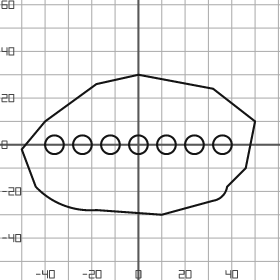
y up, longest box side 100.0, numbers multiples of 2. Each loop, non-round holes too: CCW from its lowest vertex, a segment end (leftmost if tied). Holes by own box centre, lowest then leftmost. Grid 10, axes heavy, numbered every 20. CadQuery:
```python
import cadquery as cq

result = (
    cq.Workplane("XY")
    .moveTo(10.0, -30.0)
    .lineTo(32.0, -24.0)
    .threePointArc((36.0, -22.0), (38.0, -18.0))
    .lineTo(46.0, -10.0)
    .lineTo(50.0, 10.0)
    .lineTo(32.0, 24.0)
    .lineTo(0.0, 30.0)
    .lineTo(-18.0, 26.0)
    .lineTo(-40.0, 10.0)
    .lineTo(-50.0, -2.0)
    .lineTo(-44.0, -18.0)
    .threePointArc((-32.0, -26.0), (-18.0, -28.0))
    .close()
    .moveTo(-36.0, 0.0)
    .circle(4.0)
    .moveTo(-24.0, 0.0)
    .circle(4.0)
    .moveTo(-12.0, 0.0)
    .circle(4.0)
    .moveTo(0.0, 0.0)
    .circle(4.0)
    .moveTo(12.0, 0.0)
    .circle(4.0)
    .moveTo(24.0, 0.0)
    .circle(4.0)
    .moveTo(36.0, 0.0)
    .circle(4.0)
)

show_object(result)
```